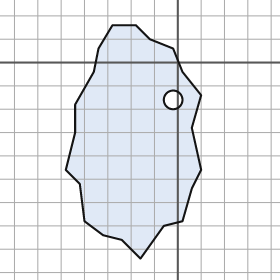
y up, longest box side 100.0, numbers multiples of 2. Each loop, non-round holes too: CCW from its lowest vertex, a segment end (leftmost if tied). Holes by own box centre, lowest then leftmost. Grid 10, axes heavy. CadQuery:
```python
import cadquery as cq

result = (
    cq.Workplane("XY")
    .moveTo(-16.0, -84.0)
    .lineTo(-6.0, -70.0)
    .lineTo(2.0, -68.0)
    .lineTo(6.0, -54.0)
    .lineTo(10.0, -46.0)
    .lineTo(6.0, -28.0)
    .lineTo(10.0, -14.0)
    .lineTo(2.0, -4.0)
    .lineTo(-2.0, 6.0)
    .lineTo(-12.0, 10.0)
    .lineTo(-18.0, 16.0)
    .lineTo(-28.0, 16.0)
    .lineTo(-34.0, 6.0)
    .lineTo(-36.0, -4.0)
    .lineTo(-44.0, -18.0)
    .lineTo(-44.0, -30.0)
    .lineTo(-48.0, -46.0)
    .lineTo(-42.0, -52.0)
    .lineTo(-40.0, -68.0)
    .lineTo(-32.0, -74.0)
    .lineTo(-24.0, -76.0)
    .close()
    .moveTo(-2.0, -16.0)
    .circle(4.0)
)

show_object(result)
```